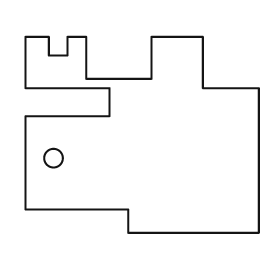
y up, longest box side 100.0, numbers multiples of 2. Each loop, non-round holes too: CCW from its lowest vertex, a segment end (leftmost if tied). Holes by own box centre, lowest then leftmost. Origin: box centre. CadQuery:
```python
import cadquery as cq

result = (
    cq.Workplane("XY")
    .moveTo(-6.0, -42.0)
    .lineTo(50.0, -42.0)
    .lineTo(50.0, 20.0)
    .lineTo(26.0, 20.0)
    .lineTo(26.0, 42.0)
    .lineTo(4.0, 42.0)
    .lineTo(4.0, 24.0)
    .lineTo(-24.0, 24.0)
    .lineTo(-24.0, 42.0)
    .lineTo(-32.0, 42.0)
    .lineTo(-32.0, 34.0)
    .lineTo(-40.0, 34.0)
    .lineTo(-40.0, 42.0)
    .lineTo(-50.0, 42.0)
    .lineTo(-50.0, 20.0)
    .lineTo(-14.0, 20.0)
    .lineTo(-14.0, 8.0)
    .lineTo(-50.0, 8.0)
    .lineTo(-50.0, -32.0)
    .lineTo(-6.0, -32.0)
    .close()
    .moveTo(-38.0, -10.0)
    .circle(4.0)
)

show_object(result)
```